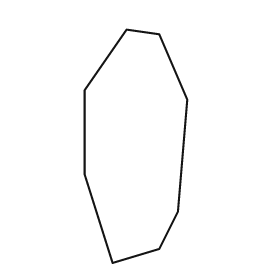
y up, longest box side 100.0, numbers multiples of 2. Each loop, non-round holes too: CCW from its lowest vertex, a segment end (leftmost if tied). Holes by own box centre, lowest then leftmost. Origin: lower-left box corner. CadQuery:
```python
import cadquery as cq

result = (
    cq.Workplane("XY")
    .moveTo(12.0, 0.0)
    .lineTo(32.0, 6.0)
    .lineTo(40.0, 22.0)
    .lineTo(44.0, 70.0)
    .lineTo(32.0, 98.0)
    .lineTo(18.0, 100.0)
    .lineTo(0.0, 74.0)
    .lineTo(0.0, 38.0)
    .close()
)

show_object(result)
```